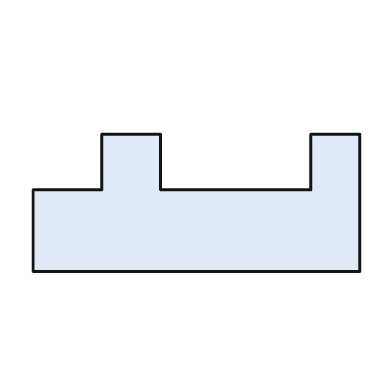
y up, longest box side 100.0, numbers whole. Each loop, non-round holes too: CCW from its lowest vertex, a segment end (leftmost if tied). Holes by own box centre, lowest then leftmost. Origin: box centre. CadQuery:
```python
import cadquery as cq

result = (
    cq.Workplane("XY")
    .moveTo(-50.0, -21.0)
    .lineTo(50.0, -21.0)
    .lineTo(50.0, 21.0)
    .lineTo(35.0, 21.0)
    .lineTo(35.0, 4.0)
    .lineTo(-11.0, 4.0)
    .lineTo(-11.0, 21.0)
    .lineTo(-29.0, 21.0)
    .lineTo(-29.0, 4.0)
    .lineTo(-50.0, 4.0)
    .close()
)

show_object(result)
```